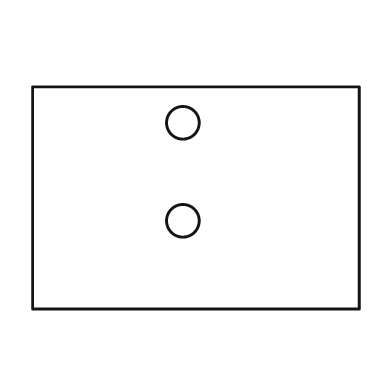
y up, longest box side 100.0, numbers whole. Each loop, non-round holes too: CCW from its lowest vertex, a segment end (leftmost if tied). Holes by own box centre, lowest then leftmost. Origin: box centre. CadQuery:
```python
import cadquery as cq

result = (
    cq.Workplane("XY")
    .moveTo(-50.0, -34.0)
    .lineTo(50.0, -34.0)
    .lineTo(50.0, 34.0)
    .lineTo(-50.0, 34.0)
    .close()
    .moveTo(-4.0, -7.0)
    .circle(5.0)
    .moveTo(-4.0, 23.0)
    .circle(5.0)
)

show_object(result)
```